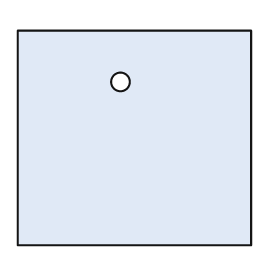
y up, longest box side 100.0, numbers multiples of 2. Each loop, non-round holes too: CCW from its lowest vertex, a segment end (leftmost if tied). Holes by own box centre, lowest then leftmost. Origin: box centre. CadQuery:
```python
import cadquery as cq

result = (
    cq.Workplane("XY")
    .moveTo(-50.0, -46.0)
    .lineTo(50.0, -46.0)
    .lineTo(50.0, 46.0)
    .lineTo(-50.0, 46.0)
    .close()
    .moveTo(-6.0, 24.0)
    .circle(4.0)
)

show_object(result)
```